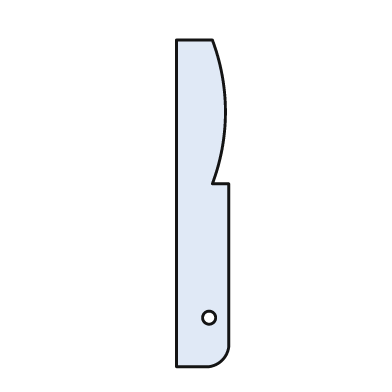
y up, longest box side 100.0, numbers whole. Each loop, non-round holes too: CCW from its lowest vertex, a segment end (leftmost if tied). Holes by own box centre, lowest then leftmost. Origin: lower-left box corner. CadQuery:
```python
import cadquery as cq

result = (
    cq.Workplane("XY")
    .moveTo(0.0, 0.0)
    .lineTo(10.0, 0.0)
    .threePointArc((14.0, 2.0), (16.0, 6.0))
    .lineTo(16.0, 56.0)
    .lineTo(11.0, 56.0)
    .threePointArc((15.0, 78.0), (11.0, 100.0))
    .lineTo(0.0, 100.0)
    .close()
    .moveTo(10.0, 15.0)
    .circle(2.0)
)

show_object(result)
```